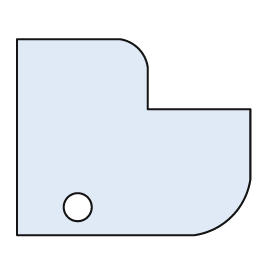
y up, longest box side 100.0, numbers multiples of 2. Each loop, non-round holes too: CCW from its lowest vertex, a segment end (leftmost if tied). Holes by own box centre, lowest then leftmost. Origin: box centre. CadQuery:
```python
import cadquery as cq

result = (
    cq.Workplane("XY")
    .moveTo(-50.0, -42.0)
    .lineTo(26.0, -42.0)
    .threePointArc((42.0, -34.0), (50.0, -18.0))
    .lineTo(50.0, 12.0)
    .lineTo(6.0, 12.0)
    .lineTo(6.0, 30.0)
    .threePointArc((2.0, 38.0), (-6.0, 42.0))
    .lineTo(-50.0, 42.0)
    .close()
    .moveTo(-24.0, -30.0)
    .circle(6.0)
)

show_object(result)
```